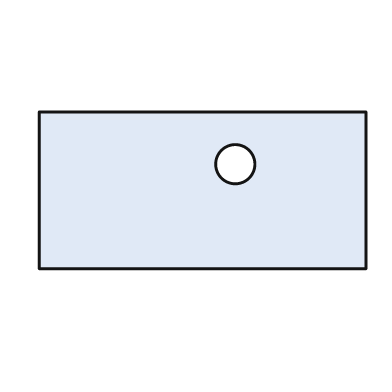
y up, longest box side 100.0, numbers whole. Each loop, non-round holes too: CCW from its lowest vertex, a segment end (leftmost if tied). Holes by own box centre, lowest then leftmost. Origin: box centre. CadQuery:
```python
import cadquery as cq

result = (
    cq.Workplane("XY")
    .moveTo(-50.0, -24.0)
    .lineTo(50.0, -24.0)
    .lineTo(50.0, 24.0)
    .lineTo(-50.0, 24.0)
    .close()
    .moveTo(10.0, 8.0)
    .circle(6.0)
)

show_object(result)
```